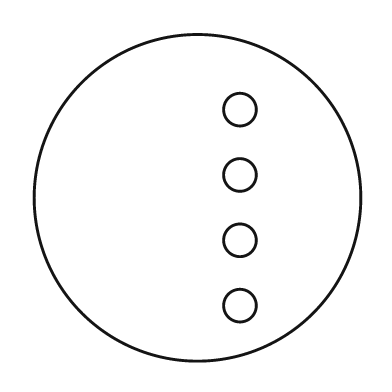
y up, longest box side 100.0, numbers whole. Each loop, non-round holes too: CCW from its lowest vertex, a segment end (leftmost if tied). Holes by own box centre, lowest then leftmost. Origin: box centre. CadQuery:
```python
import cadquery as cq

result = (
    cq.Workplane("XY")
    .moveTo(0.0, 0.0)
    .circle(50.0)
    .moveTo(13.0, -33.0)
    .circle(5.0)
    .moveTo(13.0, -13.0)
    .circle(5.0)
    .moveTo(13.0, 7.0)
    .circle(5.0)
    .moveTo(13.0, 27.0)
    .circle(5.0)
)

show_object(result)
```